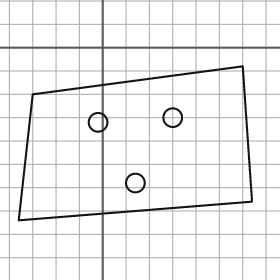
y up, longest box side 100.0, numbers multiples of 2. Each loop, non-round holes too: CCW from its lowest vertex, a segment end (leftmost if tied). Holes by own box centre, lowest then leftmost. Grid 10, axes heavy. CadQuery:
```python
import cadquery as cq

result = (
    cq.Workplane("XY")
    .moveTo(-36.0, -74.0)
    .lineTo(64.0, -66.0)
    .lineTo(60.0, -8.0)
    .lineTo(-30.0, -20.0)
    .close()
    .moveTo(14.0, -58.0)
    .circle(4.0)
    .moveTo(-2.0, -32.0)
    .circle(4.0)
    .moveTo(30.0, -30.0)
    .circle(4.0)
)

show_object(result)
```